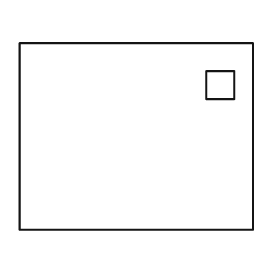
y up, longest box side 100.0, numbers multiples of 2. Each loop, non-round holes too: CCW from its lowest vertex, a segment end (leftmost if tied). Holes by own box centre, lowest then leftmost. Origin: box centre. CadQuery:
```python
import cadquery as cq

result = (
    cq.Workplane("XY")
    .moveTo(-50.0, -40.0)
    .lineTo(50.0, -40.0)
    .lineTo(50.0, 40.0)
    .lineTo(-50.0, 40.0)
    .close()
    .moveTo(30.0, 16.0)
    .lineTo(42.0, 16.0)
    .lineTo(42.0, 28.0)
    .lineTo(30.0, 28.0)
    .close()
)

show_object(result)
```